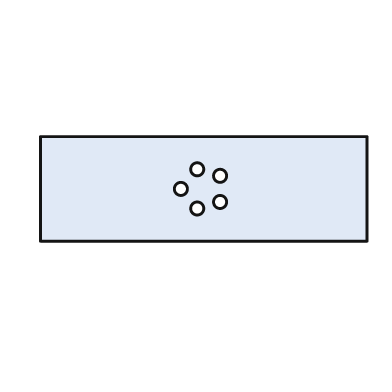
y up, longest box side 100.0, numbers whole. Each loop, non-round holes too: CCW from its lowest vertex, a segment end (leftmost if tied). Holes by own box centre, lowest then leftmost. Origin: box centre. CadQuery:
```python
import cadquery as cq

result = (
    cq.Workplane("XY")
    .moveTo(-50.0, -16.0)
    .lineTo(50.0, -16.0)
    .lineTo(50.0, 16.0)
    .lineTo(-50.0, 16.0)
    .close()
    .moveTo(-2.0, -6.0)
    .circle(2.0)
    .moveTo(5.0, -4.0)
    .circle(2.0)
    .moveTo(-7.0, 0.0)
    .circle(2.0)
    .moveTo(5.0, 4.0)
    .circle(2.0)
    .moveTo(-2.0, 6.0)
    .circle(2.0)
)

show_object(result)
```